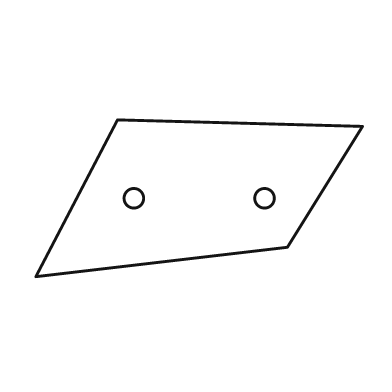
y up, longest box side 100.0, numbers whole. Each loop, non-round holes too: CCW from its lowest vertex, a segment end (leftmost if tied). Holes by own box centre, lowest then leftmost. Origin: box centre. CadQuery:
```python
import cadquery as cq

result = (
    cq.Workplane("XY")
    .moveTo(-50.0, -24.0)
    .lineTo(27.0, -15.0)
    .lineTo(50.0, 22.0)
    .lineTo(-25.0, 24.0)
    .close()
    .moveTo(-20.0, 0.0)
    .circle(3.0)
    .moveTo(20.0, 0.0)
    .circle(3.0)
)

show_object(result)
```